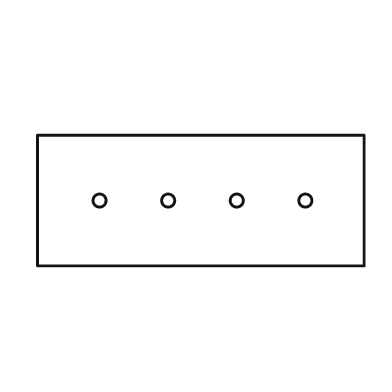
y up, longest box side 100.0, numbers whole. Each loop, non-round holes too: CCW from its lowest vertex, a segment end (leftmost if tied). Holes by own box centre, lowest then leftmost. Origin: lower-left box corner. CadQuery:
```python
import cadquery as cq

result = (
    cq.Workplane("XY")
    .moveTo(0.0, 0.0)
    .lineTo(100.0, 0.0)
    .lineTo(100.0, 40.0)
    .lineTo(0.0, 40.0)
    .close()
    .moveTo(19.0, 20.0)
    .circle(2.0)
    .moveTo(40.0, 20.0)
    .circle(2.0)
    .moveTo(61.0, 20.0)
    .circle(2.0)
    .moveTo(82.0, 20.0)
    .circle(2.0)
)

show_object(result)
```